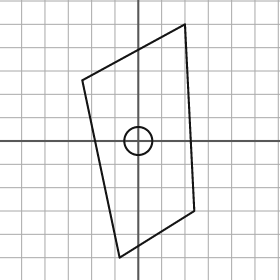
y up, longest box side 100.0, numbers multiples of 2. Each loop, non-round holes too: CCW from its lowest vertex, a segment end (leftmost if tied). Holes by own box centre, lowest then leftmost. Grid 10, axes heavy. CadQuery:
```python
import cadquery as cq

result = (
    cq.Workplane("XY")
    .moveTo(-8.0, -50.0)
    .lineTo(24.0, -30.0)
    .lineTo(20.0, 50.0)
    .lineTo(-24.0, 26.0)
    .close()
    .moveTo(0.0, 0.0)
    .circle(6.0)
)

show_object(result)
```